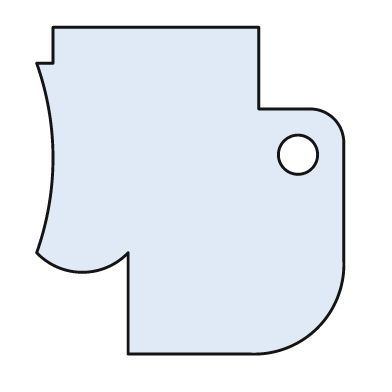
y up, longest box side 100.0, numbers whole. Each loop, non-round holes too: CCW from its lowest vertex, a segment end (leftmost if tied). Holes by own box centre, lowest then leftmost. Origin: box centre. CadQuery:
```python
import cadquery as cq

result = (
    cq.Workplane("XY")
    .moveTo(-19.0, -50.0)
    .lineTo(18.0, -50.0)
    .threePointArc((39.0, -42.0), (47.0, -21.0))
    .lineTo(47.0, 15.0)
    .threePointArc((44.0, 22.0), (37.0, 25.0))
    .lineTo(21.0, 25.0)
    .lineTo(21.0, 50.0)
    .lineTo(-42.0, 50.0)
    .lineTo(-42.0, 39.0)
    .lineTo(-47.0, 39.0)
    .threePointArc((-42.0, 10.0), (-47.0, -19.0))
    .threePointArc((-33.0, -25.0), (-19.0, -19.0))
    .close()
    .moveTo(33.0, 11.0)
    .circle(6.0)
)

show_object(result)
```